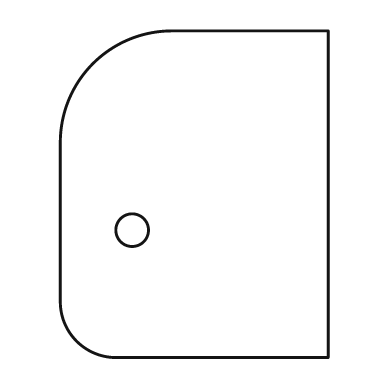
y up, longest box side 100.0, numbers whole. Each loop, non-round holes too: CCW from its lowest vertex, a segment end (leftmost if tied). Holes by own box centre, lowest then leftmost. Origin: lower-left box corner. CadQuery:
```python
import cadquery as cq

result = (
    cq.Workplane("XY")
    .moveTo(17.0, 0.0)
    .lineTo(82.0, 0.0)
    .lineTo(82.0, 100.0)
    .lineTo(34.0, 100.0)
    .threePointArc((10.0, 90.0), (0.0, 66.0))
    .lineTo(0.0, 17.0)
    .threePointArc((5.0, 5.0), (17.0, 0.0))
    .close()
    .moveTo(22.0, 39.0)
    .circle(5.0)
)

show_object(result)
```